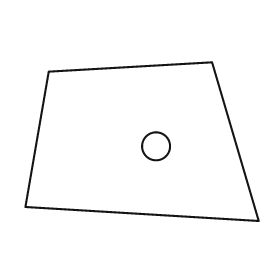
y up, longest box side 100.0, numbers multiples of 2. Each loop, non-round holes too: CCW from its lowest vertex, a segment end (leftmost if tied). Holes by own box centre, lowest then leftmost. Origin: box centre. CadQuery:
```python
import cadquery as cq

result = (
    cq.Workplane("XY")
    .moveTo(50.0, -34.0)
    .lineTo(30.0, 34.0)
    .lineTo(-40.0, 30.0)
    .lineTo(-50.0, -28.0)
    .close()
    .moveTo(6.0, -2.0)
    .circle(6.0)
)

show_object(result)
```